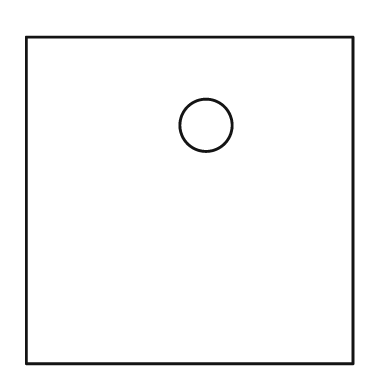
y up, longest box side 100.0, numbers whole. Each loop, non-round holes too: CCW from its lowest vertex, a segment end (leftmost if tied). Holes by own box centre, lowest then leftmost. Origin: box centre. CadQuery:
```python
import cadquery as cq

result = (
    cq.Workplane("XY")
    .moveTo(-50.0, -50.0)
    .lineTo(50.0, -50.0)
    .lineTo(50.0, 50.0)
    .lineTo(-50.0, 50.0)
    .close()
    .moveTo(5.0, 23.0)
    .circle(8.0)
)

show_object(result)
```